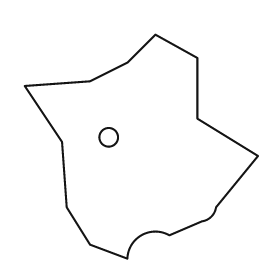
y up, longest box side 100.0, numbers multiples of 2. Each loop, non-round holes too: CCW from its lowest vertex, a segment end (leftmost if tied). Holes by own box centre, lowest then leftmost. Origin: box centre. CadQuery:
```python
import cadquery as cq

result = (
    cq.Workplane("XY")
    .moveTo(-6.0, -48.0)
    .threePointArc((0.0, -38.0), (12.0, -38.0))
    .lineTo(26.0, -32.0)
    .threePointArc((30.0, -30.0), (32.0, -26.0))
    .lineTo(50.0, -4.0)
    .lineTo(24.0, 12.0)
    .lineTo(24.0, 38.0)
    .lineTo(6.0, 48.0)
    .lineTo(-6.0, 36.0)
    .lineTo(-22.0, 28.0)
    .lineTo(-50.0, 26.0)
    .lineTo(-34.0, 2.0)
    .lineTo(-32.0, -26.0)
    .lineTo(-22.0, -42.0)
    .close()
    .moveTo(-14.0, 4.0)
    .circle(4.0)
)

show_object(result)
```